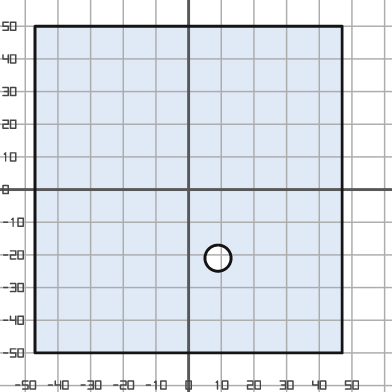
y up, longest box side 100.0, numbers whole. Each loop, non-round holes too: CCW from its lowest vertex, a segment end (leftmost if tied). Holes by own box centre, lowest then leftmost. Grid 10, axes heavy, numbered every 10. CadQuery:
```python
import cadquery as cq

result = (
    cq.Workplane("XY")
    .moveTo(-47.0, -50.0)
    .lineTo(47.0, -50.0)
    .lineTo(47.0, 50.0)
    .lineTo(-47.0, 50.0)
    .close()
    .moveTo(9.0, -21.0)
    .circle(4.0)
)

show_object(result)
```